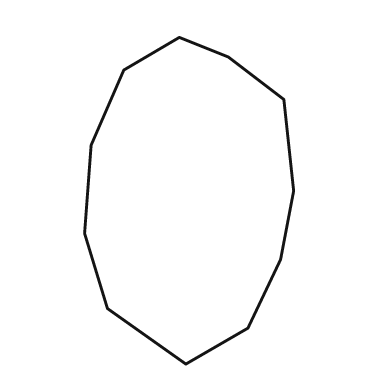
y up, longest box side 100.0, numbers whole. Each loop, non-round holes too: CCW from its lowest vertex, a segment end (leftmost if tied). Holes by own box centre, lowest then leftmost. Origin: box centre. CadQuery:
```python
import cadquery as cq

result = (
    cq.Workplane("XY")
    .moveTo(-1.0, -50.0)
    .lineTo(18.0, -39.0)
    .lineTo(28.0, -18.0)
    .lineTo(32.0, 3.0)
    .lineTo(29.0, 31.0)
    .lineTo(12.0, 44.0)
    .lineTo(-3.0, 50.0)
    .lineTo(-20.0, 40.0)
    .lineTo(-30.0, 17.0)
    .lineTo(-32.0, -10.0)
    .lineTo(-25.0, -33.0)
    .close()
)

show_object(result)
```